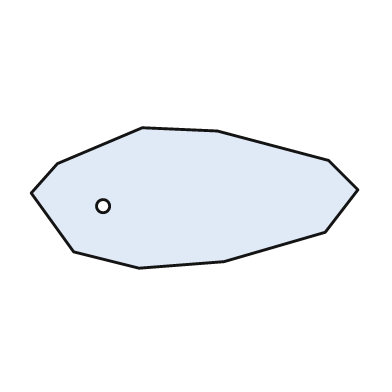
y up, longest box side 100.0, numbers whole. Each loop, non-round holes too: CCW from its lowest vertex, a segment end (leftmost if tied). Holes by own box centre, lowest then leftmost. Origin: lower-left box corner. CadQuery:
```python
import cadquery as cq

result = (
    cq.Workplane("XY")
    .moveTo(33.0, 0.0)
    .lineTo(59.0, 2.0)
    .lineTo(90.0, 11.0)
    .lineTo(100.0, 24.0)
    .lineTo(91.0, 33.0)
    .lineTo(57.0, 42.0)
    .lineTo(34.0, 43.0)
    .lineTo(8.0, 32.0)
    .lineTo(0.0, 23.0)
    .lineTo(13.0, 5.0)
    .close()
    .moveTo(22.0, 19.0)
    .circle(2.0)
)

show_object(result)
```